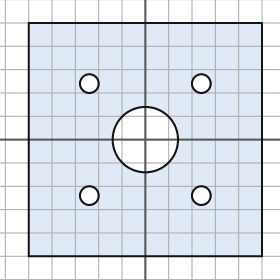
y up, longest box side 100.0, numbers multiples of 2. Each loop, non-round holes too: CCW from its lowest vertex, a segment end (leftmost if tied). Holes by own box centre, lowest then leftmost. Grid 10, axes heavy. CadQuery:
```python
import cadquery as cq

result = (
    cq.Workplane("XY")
    .moveTo(-50.0, -50.0)
    .lineTo(50.0, -50.0)
    .lineTo(50.0, 50.0)
    .lineTo(-50.0, 50.0)
    .close()
    .moveTo(-24.0, -24.0)
    .circle(4.0)
    .moveTo(24.0, -24.0)
    .circle(4.0)
    .moveTo(0.0, 0.0)
    .circle(14.0)
    .moveTo(-24.0, 24.0)
    .circle(4.0)
    .moveTo(24.0, 24.0)
    .circle(4.0)
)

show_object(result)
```